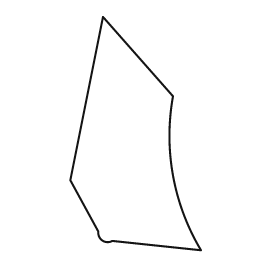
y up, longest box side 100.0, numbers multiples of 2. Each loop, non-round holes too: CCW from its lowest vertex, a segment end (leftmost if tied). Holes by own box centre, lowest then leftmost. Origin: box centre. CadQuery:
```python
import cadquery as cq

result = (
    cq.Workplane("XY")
    .moveTo(28.0, -50.0)
    .threePointArc((16.0, -18.0), (16.0, 16.0))
    .lineTo(-14.0, 50.0)
    .lineTo(-28.0, -20.0)
    .lineTo(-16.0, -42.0)
    .threePointArc((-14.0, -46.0), (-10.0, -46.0))
    .close()
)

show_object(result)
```